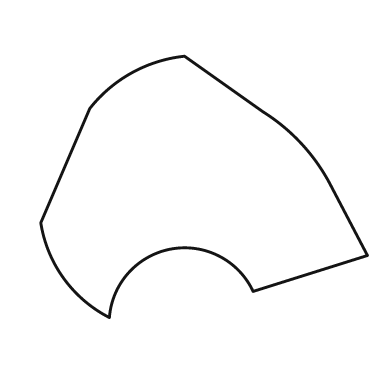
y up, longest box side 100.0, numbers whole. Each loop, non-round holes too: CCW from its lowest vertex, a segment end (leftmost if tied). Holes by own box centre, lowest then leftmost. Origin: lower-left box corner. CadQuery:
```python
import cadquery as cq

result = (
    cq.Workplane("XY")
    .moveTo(21.0, 0.0)
    .threePointArc((40.0, 21.0), (65.0, 8.0))
    .lineTo(100.0, 19.0)
    .lineTo(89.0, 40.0)
    .threePointArc((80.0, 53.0), (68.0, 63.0))
    .lineTo(44.0, 80.0)
    .threePointArc((28.0, 75.0), (15.0, 64.0))
    .lineTo(0.0, 29.0)
    .threePointArc((7.0, 12.0), (21.0, 0.0))
    .close()
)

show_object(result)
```